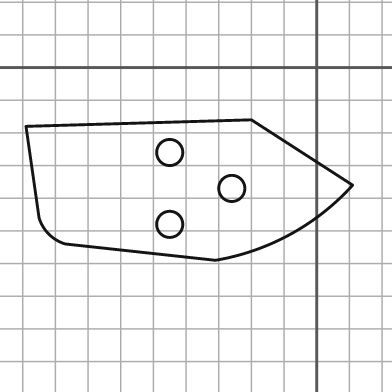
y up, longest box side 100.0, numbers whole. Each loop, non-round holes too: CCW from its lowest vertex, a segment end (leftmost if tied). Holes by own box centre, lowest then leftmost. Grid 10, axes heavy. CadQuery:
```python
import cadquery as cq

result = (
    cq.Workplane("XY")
    .moveTo(-31.0, -59.0)
    .threePointArc((-8.0, -51.0), (11.0, -36.0))
    .lineTo(-20.0, -16.0)
    .lineTo(-89.0, -18.0)
    .lineTo(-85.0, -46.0)
    .threePointArc((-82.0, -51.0), (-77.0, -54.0))
    .close()
    .moveTo(-45.0, -48.0)
    .circle(4.0)
    .moveTo(-26.0, -37.0)
    .circle(4.0)
    .moveTo(-45.0, -26.0)
    .circle(4.0)
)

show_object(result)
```